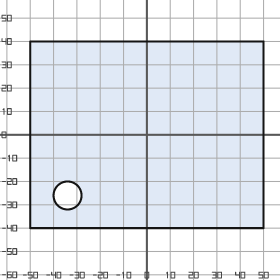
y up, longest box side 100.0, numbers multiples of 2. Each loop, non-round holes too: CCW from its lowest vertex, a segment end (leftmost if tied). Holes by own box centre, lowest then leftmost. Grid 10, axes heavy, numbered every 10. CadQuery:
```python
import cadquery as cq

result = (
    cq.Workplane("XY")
    .moveTo(-50.0, -40.0)
    .lineTo(50.0, -40.0)
    .lineTo(50.0, 40.0)
    .lineTo(-50.0, 40.0)
    .close()
    .moveTo(-34.0, -26.0)
    .circle(6.0)
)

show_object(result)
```